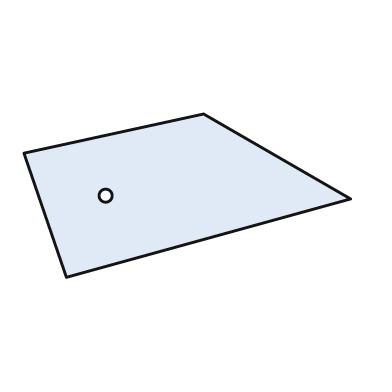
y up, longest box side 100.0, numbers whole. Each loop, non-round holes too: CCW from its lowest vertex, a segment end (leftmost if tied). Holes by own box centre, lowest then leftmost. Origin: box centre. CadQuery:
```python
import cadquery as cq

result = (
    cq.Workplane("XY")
    .moveTo(-37.0, -25.0)
    .lineTo(50.0, -1.0)
    .lineTo(5.0, 25.0)
    .lineTo(-50.0, 13.0)
    .close()
    .moveTo(-25.0, 0.0)
    .circle(2.0)
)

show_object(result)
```